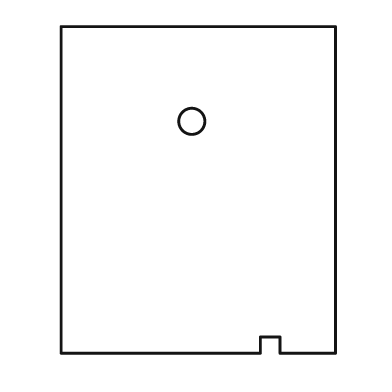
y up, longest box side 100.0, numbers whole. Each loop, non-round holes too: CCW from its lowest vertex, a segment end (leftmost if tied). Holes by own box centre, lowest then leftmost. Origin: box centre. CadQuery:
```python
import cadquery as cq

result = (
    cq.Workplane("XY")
    .moveTo(-42.0, -50.0)
    .lineTo(19.0, -50.0)
    .lineTo(19.0, -45.0)
    .lineTo(25.0, -45.0)
    .lineTo(25.0, -50.0)
    .lineTo(42.0, -50.0)
    .lineTo(42.0, 50.0)
    .lineTo(-42.0, 50.0)
    .close()
    .moveTo(-2.0, 21.0)
    .circle(4.0)
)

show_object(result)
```